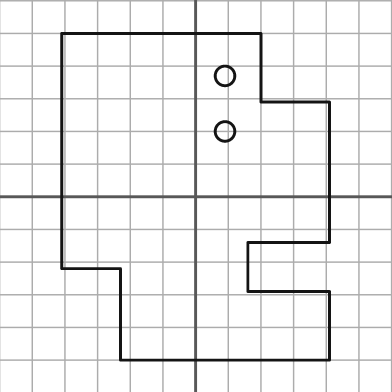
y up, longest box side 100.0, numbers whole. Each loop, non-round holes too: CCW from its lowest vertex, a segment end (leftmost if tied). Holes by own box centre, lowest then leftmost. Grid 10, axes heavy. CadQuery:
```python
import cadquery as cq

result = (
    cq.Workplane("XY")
    .moveTo(-23.0, -50.0)
    .lineTo(41.0, -50.0)
    .lineTo(41.0, -29.0)
    .lineTo(16.0, -29.0)
    .lineTo(16.0, -14.0)
    .lineTo(41.0, -14.0)
    .lineTo(41.0, 29.0)
    .lineTo(20.0, 29.0)
    .lineTo(20.0, 50.0)
    .lineTo(-41.0, 50.0)
    .lineTo(-41.0, -22.0)
    .lineTo(-23.0, -22.0)
    .close()
    .moveTo(9.0, 20.0)
    .circle(3.0)
    .moveTo(9.0, 37.0)
    .circle(3.0)
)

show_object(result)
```